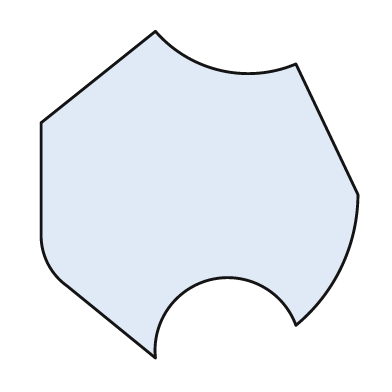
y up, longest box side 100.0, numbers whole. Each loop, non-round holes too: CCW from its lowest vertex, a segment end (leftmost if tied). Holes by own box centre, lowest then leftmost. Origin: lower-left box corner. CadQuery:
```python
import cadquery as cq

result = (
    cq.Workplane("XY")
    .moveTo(35.0, 0.0)
    .threePointArc((52.0, 24.0), (78.0, 10.0))
    .threePointArc((92.0, 28.0), (97.0, 50.0))
    .lineTo(78.0, 90.0)
    .threePointArc((55.0, 88.0), (35.0, 100.0))
    .lineTo(0.0, 72.0)
    .lineTo(0.0, 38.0)
    .threePointArc((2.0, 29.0), (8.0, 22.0))
    .close()
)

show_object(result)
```